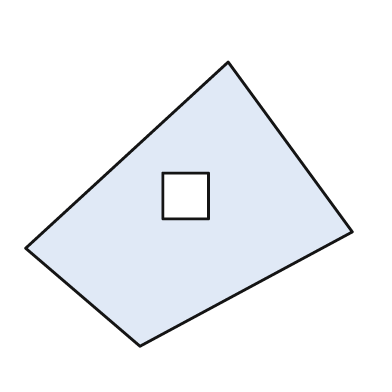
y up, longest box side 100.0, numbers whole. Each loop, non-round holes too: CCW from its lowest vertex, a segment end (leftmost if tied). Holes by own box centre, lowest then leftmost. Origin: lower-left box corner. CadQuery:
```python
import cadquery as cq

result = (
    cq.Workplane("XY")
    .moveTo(35.0, 0.0)
    .lineTo(100.0, 35.0)
    .lineTo(62.0, 87.0)
    .lineTo(0.0, 30.0)
    .close()
    .moveTo(42.0, 39.0)
    .lineTo(56.0, 39.0)
    .lineTo(56.0, 53.0)
    .lineTo(42.0, 53.0)
    .close()
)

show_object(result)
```